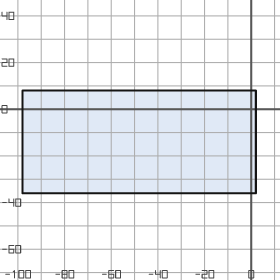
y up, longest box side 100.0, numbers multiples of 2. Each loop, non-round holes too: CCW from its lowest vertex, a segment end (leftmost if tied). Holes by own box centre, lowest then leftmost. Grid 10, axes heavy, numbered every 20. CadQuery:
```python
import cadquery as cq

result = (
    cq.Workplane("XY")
    .moveTo(-98.0, -36.0)
    .lineTo(2.0, -36.0)
    .lineTo(2.0, 8.0)
    .lineTo(-98.0, 8.0)
    .close()
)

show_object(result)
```